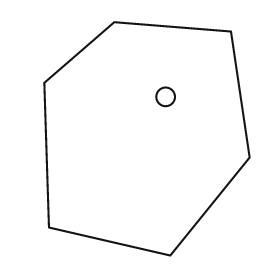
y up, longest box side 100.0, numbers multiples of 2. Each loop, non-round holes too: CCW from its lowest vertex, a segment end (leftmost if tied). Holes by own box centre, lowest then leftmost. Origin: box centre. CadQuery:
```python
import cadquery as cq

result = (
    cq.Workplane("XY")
    .moveTo(10.0, -50.0)
    .lineTo(44.0, -8.0)
    .lineTo(36.0, 46.0)
    .lineTo(-14.0, 50.0)
    .lineTo(-44.0, 24.0)
    .lineTo(-42.0, -38.0)
    .close()
    .moveTo(8.0, 18.0)
    .circle(4.0)
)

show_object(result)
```